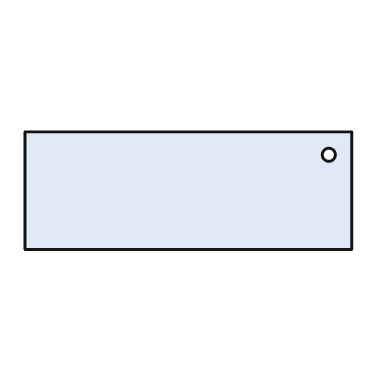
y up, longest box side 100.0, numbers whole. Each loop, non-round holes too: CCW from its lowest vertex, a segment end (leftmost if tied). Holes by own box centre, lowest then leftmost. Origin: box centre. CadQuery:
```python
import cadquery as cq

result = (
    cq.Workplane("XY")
    .moveTo(-50.0, -18.0)
    .lineTo(50.0, -18.0)
    .lineTo(50.0, 18.0)
    .lineTo(-50.0, 18.0)
    .close()
    .moveTo(43.0, 11.0)
    .circle(2.0)
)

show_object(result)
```